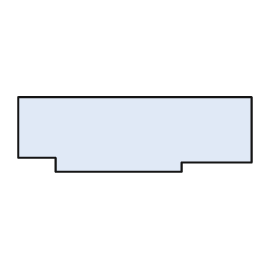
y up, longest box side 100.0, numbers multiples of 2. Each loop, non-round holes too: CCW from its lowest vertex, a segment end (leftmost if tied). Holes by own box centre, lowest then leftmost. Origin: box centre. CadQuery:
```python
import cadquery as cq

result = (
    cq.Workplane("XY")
    .moveTo(-34.0, -16.0)
    .lineTo(20.0, -16.0)
    .lineTo(20.0, -12.0)
    .lineTo(50.0, -12.0)
    .lineTo(50.0, 16.0)
    .lineTo(-50.0, 16.0)
    .lineTo(-50.0, -10.0)
    .lineTo(-34.0, -10.0)
    .close()
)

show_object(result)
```